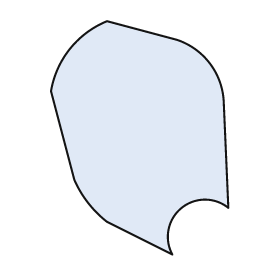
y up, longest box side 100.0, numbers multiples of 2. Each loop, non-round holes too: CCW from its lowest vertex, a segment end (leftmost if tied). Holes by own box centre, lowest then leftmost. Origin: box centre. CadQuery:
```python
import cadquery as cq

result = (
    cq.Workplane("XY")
    .moveTo(14.0, -50.0)
    .threePointArc((18.0, -30.0), (38.0, -30.0))
    .lineTo(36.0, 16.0)
    .threePointArc((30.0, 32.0), (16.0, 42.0))
    .lineTo(-14.0, 50.0)
    .threePointArc((-30.0, 38.0), (-38.0, 20.0))
    .lineTo(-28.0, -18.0)
    .threePointArc((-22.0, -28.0), (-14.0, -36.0))
    .close()
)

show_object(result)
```